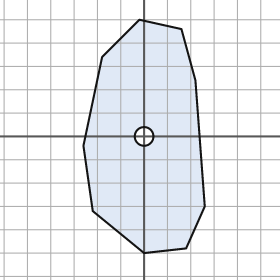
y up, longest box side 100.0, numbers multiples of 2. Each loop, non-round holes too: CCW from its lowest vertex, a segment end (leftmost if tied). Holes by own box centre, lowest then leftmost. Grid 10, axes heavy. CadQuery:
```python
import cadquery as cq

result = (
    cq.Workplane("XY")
    .moveTo(0.0, -50.0)
    .lineTo(18.0, -48.0)
    .lineTo(26.0, -30.0)
    .lineTo(22.0, 24.0)
    .lineTo(16.0, 46.0)
    .lineTo(-2.0, 50.0)
    .lineTo(-18.0, 34.0)
    .lineTo(-26.0, -4.0)
    .lineTo(-22.0, -32.0)
    .close()
    .moveTo(0.0, 0.0)
    .circle(4.0)
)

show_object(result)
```